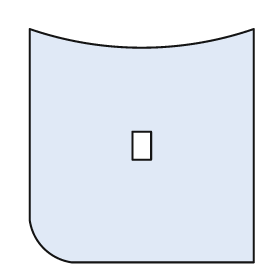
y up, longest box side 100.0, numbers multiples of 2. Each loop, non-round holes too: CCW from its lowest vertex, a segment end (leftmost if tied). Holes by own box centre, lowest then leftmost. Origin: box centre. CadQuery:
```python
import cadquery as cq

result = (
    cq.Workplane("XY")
    .moveTo(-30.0, -50.0)
    .lineTo(48.0, -50.0)
    .lineTo(48.0, 50.0)
    .threePointArc((0.0, 42.0), (-48.0, 50.0))
    .lineTo(-48.0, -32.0)
    .threePointArc((-42.0, -44.0), (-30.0, -50.0))
    .close()
    .moveTo(-4.0, -6.0)
    .lineTo(4.0, -6.0)
    .lineTo(4.0, 6.0)
    .lineTo(-4.0, 6.0)
    .close()
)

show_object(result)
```